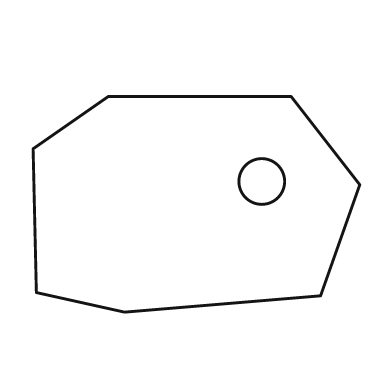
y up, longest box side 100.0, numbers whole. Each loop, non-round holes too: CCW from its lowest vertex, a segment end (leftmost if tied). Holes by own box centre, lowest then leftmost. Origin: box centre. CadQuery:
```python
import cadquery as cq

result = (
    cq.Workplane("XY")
    .moveTo(-22.0, -33.0)
    .lineTo(38.0, -28.0)
    .lineTo(50.0, 6.0)
    .lineTo(29.0, 33.0)
    .lineTo(-27.0, 33.0)
    .lineTo(-50.0, 17.0)
    .lineTo(-49.0, -27.0)
    .close()
    .moveTo(20.0, 7.0)
    .circle(7.0)
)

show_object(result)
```